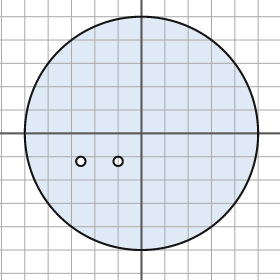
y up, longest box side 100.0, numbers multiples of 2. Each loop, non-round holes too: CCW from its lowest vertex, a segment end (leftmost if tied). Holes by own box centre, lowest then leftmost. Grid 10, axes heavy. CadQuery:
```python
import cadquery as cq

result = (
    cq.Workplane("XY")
    .moveTo(0.0, 0.0)
    .circle(50.0)
    .moveTo(-26.0, -12.0)
    .circle(2.0)
    .moveTo(-10.0, -12.0)
    .circle(2.0)
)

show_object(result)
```